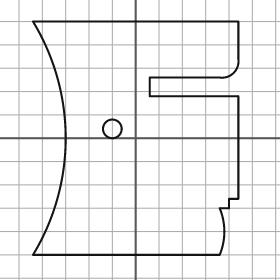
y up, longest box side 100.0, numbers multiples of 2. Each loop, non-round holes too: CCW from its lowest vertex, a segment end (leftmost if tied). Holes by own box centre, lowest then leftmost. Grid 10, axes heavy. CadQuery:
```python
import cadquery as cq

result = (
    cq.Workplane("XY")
    .moveTo(-44.0, -50.0)
    .lineTo(36.0, -50.0)
    .threePointArc((38.0, -40.0), (36.0, -30.0))
    .lineTo(40.0, -30.0)
    .lineTo(40.0, -26.0)
    .lineTo(44.0, -26.0)
    .lineTo(44.0, 18.0)
    .lineTo(6.0, 18.0)
    .lineTo(6.0, 26.0)
    .lineTo(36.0, 26.0)
    .threePointArc((42.0, 28.0), (44.0, 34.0))
    .lineTo(44.0, 50.0)
    .lineTo(-44.0, 50.0)
    .threePointArc((-30.0, 0.0), (-44.0, -50.0))
    .close()
    .moveTo(-10.0, 4.0)
    .circle(4.0)
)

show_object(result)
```